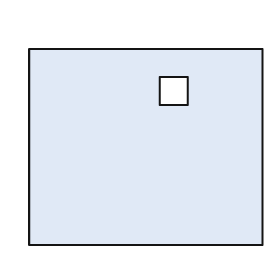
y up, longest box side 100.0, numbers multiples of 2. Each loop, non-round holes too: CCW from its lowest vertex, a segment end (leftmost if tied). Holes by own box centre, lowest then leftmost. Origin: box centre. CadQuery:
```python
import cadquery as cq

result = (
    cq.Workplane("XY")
    .moveTo(-50.0, -42.0)
    .lineTo(50.0, -42.0)
    .lineTo(50.0, 42.0)
    .lineTo(-50.0, 42.0)
    .close()
    .moveTo(6.0, 18.0)
    .lineTo(18.0, 18.0)
    .lineTo(18.0, 30.0)
    .lineTo(6.0, 30.0)
    .close()
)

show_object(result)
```